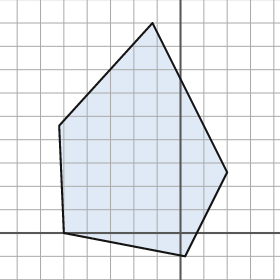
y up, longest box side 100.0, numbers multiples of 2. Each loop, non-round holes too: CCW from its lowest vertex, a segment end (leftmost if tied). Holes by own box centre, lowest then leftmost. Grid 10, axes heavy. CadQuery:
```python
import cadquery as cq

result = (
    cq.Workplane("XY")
    .moveTo(2.0, -10.0)
    .lineTo(20.0, 26.0)
    .lineTo(-12.0, 90.0)
    .lineTo(-52.0, 46.0)
    .lineTo(-50.0, 0.0)
    .close()
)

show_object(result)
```